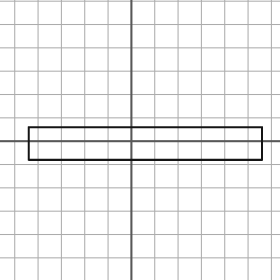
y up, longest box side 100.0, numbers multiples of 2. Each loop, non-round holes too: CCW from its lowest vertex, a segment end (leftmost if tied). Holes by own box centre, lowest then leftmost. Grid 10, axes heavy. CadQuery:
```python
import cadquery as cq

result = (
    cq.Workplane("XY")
    .moveTo(-44.0, -8.0)
    .lineTo(56.0, -8.0)
    .lineTo(56.0, 6.0)
    .lineTo(-44.0, 6.0)
    .close()
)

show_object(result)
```